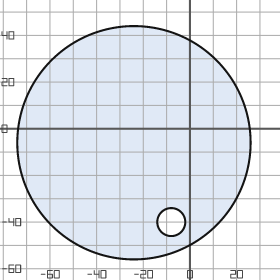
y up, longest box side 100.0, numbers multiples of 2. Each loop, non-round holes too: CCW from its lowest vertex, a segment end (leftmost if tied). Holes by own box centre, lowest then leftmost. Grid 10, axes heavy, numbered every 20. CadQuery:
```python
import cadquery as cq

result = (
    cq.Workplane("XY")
    .moveTo(-24.0, -6.0)
    .circle(50.0)
    .moveTo(-8.0, -40.0)
    .circle(6.0)
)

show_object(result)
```